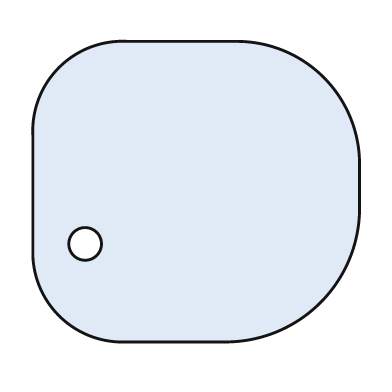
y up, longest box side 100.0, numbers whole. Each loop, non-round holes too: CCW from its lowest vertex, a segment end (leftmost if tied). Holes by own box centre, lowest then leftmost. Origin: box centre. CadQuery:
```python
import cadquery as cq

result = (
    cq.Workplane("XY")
    .moveTo(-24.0, -46.0)
    .lineTo(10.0, -46.0)
    .threePointArc((38.0, -34.0), (50.0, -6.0))
    .lineTo(50.0, 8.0)
    .threePointArc((39.0, 35.0), (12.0, 46.0))
    .lineTo(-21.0, 46.0)
    .threePointArc((-42.0, 38.0), (-50.0, 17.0))
    .lineTo(-50.0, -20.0)
    .threePointArc((-42.0, -38.0), (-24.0, -46.0))
    .close()
    .moveTo(-34.0, -16.0)
    .circle(5.0)
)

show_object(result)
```